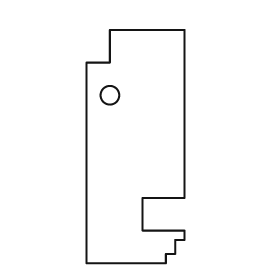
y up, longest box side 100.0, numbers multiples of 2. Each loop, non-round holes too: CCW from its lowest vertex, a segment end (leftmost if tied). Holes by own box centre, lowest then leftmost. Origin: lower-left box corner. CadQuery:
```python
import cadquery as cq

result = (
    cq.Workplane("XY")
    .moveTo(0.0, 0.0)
    .lineTo(34.0, 0.0)
    .lineTo(34.0, 4.0)
    .lineTo(38.0, 4.0)
    .lineTo(38.0, 10.0)
    .lineTo(42.0, 10.0)
    .lineTo(42.0, 14.0)
    .lineTo(24.0, 14.0)
    .lineTo(24.0, 28.0)
    .lineTo(42.0, 28.0)
    .lineTo(42.0, 100.0)
    .lineTo(10.0, 100.0)
    .lineTo(10.0, 86.0)
    .lineTo(0.0, 86.0)
    .close()
    .moveTo(10.0, 72.0)
    .circle(4.0)
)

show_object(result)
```